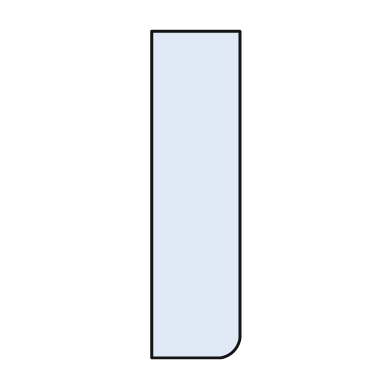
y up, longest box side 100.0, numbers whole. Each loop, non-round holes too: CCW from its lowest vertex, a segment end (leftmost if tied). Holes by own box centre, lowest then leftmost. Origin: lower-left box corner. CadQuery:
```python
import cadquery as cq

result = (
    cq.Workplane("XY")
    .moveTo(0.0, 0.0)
    .lineTo(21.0, 0.0)
    .threePointArc((25.0, 2.0), (27.0, 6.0))
    .lineTo(27.0, 100.0)
    .lineTo(0.0, 100.0)
    .close()
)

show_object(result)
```